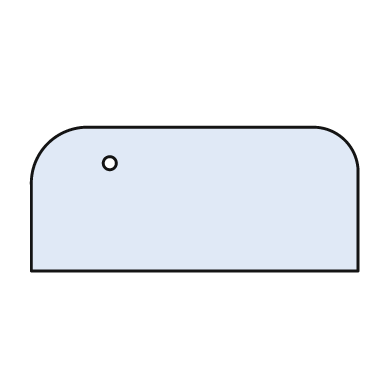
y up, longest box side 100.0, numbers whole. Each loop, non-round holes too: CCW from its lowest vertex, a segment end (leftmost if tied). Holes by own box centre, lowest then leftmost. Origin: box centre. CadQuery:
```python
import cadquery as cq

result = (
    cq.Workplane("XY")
    .moveTo(-50.0, -22.0)
    .lineTo(50.0, -22.0)
    .lineTo(50.0, 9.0)
    .threePointArc((46.0, 18.0), (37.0, 22.0))
    .lineTo(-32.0, 22.0)
    .threePointArc((-45.0, 17.0), (-50.0, 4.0))
    .close()
    .moveTo(-26.0, 11.0)
    .circle(2.0)
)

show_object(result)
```